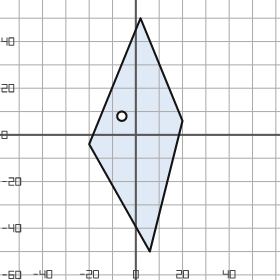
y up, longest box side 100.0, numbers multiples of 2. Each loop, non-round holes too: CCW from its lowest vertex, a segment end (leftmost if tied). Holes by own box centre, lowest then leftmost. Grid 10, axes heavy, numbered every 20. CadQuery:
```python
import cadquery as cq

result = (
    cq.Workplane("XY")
    .moveTo(6.0, -50.0)
    .lineTo(20.0, 6.0)
    .lineTo(2.0, 50.0)
    .lineTo(-20.0, -4.0)
    .close()
    .moveTo(-6.0, 8.0)
    .circle(2.0)
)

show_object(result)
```